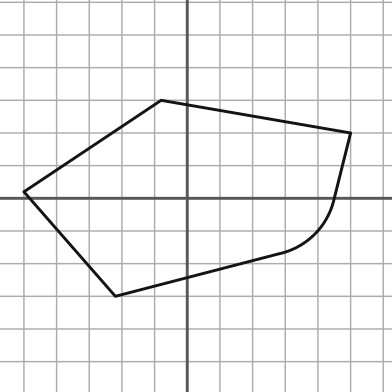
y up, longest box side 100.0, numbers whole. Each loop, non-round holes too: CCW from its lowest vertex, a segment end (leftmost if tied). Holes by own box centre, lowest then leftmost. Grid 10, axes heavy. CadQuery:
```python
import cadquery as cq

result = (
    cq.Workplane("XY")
    .moveTo(-22.0, -30.0)
    .lineTo(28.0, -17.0)
    .threePointArc((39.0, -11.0), (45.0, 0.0))
    .lineTo(50.0, 20.0)
    .lineTo(-8.0, 30.0)
    .lineTo(-50.0, 2.0)
    .close()
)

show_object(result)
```